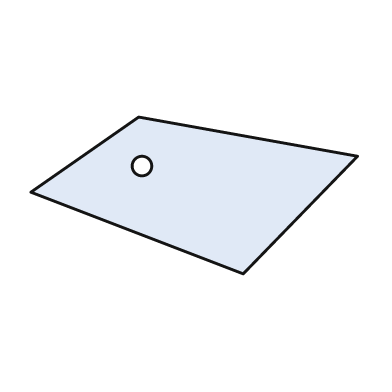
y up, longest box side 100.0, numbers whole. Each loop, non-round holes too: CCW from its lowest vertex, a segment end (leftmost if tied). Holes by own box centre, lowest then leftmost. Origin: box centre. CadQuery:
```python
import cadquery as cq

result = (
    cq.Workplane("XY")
    .moveTo(15.0, -24.0)
    .lineTo(50.0, 12.0)
    .lineTo(-17.0, 24.0)
    .lineTo(-50.0, 1.0)
    .close()
    .moveTo(-16.0, 9.0)
    .circle(3.0)
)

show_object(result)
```